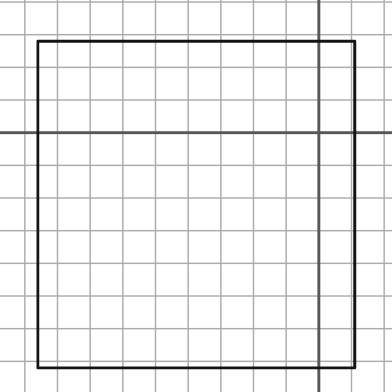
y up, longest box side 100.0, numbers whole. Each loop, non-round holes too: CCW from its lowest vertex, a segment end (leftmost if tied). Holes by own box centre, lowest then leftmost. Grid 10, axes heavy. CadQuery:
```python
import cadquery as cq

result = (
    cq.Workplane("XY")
    .moveTo(-86.0, -72.0)
    .lineTo(11.0, -72.0)
    .lineTo(11.0, 28.0)
    .lineTo(-86.0, 28.0)
    .close()
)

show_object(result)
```